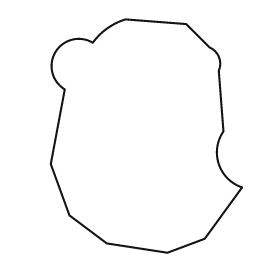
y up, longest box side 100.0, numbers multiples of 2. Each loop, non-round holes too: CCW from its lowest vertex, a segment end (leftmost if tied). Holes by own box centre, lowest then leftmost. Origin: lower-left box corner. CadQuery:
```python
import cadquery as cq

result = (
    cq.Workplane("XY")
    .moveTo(50.0, 0.0)
    .lineTo(66.0, 6.0)
    .lineTo(82.0, 28.0)
    .threePointArc((72.0, 38.0), (74.0, 52.0))
    .lineTo(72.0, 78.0)
    .threePointArc((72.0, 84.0), (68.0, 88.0))
    .lineTo(58.0, 98.0)
    .lineTo(32.0, 100.0)
    .threePointArc((24.0, 96.0), (18.0, 90.0))
    .threePointArc((2.0, 86.0), (6.0, 70.0))
    .lineTo(0.0, 38.0)
    .lineTo(8.0, 16.0)
    .lineTo(24.0, 4.0)
    .close()
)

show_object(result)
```